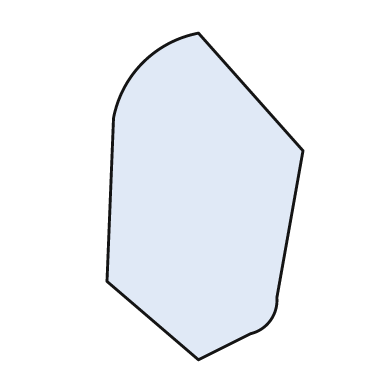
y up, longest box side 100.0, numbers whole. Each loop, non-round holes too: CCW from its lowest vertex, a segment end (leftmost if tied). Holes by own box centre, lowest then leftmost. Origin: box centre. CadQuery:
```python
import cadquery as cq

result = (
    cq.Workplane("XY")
    .moveTo(-2.0, -50.0)
    .lineTo(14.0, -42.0)
    .threePointArc((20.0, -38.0), (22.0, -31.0))
    .lineTo(30.0, 14.0)
    .lineTo(-2.0, 50.0)
    .threePointArc((-19.0, 41.0), (-28.0, 24.0))
    .lineTo(-30.0, -26.0)
    .close()
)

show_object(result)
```